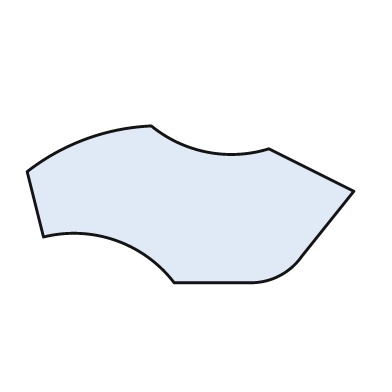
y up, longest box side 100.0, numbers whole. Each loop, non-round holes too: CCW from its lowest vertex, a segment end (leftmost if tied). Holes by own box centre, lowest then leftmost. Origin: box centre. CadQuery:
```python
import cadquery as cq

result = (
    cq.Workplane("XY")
    .moveTo(-5.0, -24.0)
    .lineTo(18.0, -24.0)
    .threePointArc((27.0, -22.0), (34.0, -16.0))
    .lineTo(50.0, 4.0)
    .lineTo(24.0, 17.0)
    .threePointArc((5.0, 16.0), (-12.0, 24.0))
    .threePointArc((-32.0, 20.0), (-50.0, 10.0))
    .lineTo(-45.0, -10.0)
    .threePointArc((-23.0, -11.0), (-5.0, -24.0))
    .close()
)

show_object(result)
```